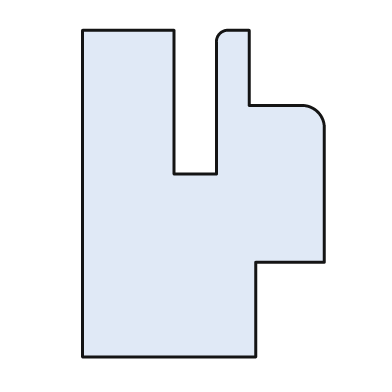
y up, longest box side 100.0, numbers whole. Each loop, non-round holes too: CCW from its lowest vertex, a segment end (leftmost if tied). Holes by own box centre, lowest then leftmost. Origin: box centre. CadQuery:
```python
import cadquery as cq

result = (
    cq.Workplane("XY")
    .moveTo(-37.0, -50.0)
    .lineTo(16.0, -50.0)
    .lineTo(16.0, -21.0)
    .lineTo(37.0, -21.0)
    .lineTo(37.0, 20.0)
    .threePointArc((35.0, 25.0), (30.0, 27.0))
    .lineTo(14.0, 27.0)
    .lineTo(14.0, 50.0)
    .lineTo(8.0, 50.0)
    .threePointArc((5.0, 49.0), (4.0, 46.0))
    .lineTo(4.0, 6.0)
    .lineTo(-9.0, 6.0)
    .lineTo(-9.0, 50.0)
    .lineTo(-37.0, 50.0)
    .close()
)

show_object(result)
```